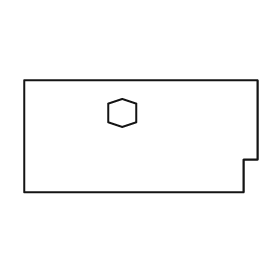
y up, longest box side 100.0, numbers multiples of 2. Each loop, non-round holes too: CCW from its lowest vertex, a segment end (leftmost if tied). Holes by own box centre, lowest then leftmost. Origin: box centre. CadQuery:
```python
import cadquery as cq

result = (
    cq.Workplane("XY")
    .moveTo(-50.0, -24.0)
    .lineTo(44.0, -24.0)
    .lineTo(44.0, -10.0)
    .lineTo(50.0, -10.0)
    .lineTo(50.0, 24.0)
    .lineTo(-50.0, 24.0)
    .close()
    .moveTo(-8.0, 4.0)
    .lineTo(-2.0, 6.0)
    .lineTo(-2.0, 14.0)
    .lineTo(-8.0, 16.0)
    .lineTo(-14.0, 14.0)
    .lineTo(-14.0, 6.0)
    .close()
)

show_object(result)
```